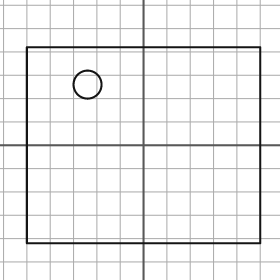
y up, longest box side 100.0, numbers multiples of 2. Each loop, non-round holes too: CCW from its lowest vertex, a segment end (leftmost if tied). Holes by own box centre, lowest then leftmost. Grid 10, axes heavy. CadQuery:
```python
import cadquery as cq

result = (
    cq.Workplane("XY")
    .moveTo(-50.0, -42.0)
    .lineTo(50.0, -42.0)
    .lineTo(50.0, 42.0)
    .lineTo(-50.0, 42.0)
    .close()
    .moveTo(-24.0, 26.0)
    .circle(6.0)
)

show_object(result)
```